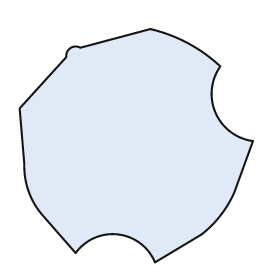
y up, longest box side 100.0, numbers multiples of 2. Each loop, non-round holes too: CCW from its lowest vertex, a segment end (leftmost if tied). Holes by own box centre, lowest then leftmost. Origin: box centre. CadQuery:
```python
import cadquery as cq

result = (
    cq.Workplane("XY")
    .moveTo(8.0, -50.0)
    .lineTo(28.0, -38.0)
    .threePointArc((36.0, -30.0), (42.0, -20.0))
    .lineTo(50.0, 2.0)
    .threePointArc((34.0, 14.0), (36.0, 34.0))
    .threePointArc((22.0, 44.0), (6.0, 50.0))
    .lineTo(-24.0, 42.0)
    .threePointArc((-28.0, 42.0), (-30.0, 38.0))
    .lineTo(-50.0, 16.0)
    .lineTo(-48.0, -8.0)
    .threePointArc((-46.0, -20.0), (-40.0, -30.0))
    .lineTo(-26.0, -46.0)
    .threePointArc((-8.0, -38.0), (8.0, -50.0))
    .close()
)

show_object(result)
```